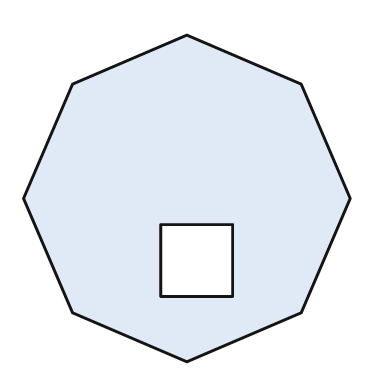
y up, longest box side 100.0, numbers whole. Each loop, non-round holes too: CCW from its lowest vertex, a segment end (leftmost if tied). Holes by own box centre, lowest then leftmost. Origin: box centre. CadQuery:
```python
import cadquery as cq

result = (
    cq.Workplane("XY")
    .moveTo(0.0, -50.0)
    .lineTo(35.0, -35.0)
    .lineTo(50.0, 0.0)
    .lineTo(35.0, 35.0)
    .lineTo(0.0, 50.0)
    .lineTo(-35.0, 35.0)
    .lineTo(-50.0, 0.0)
    .lineTo(-35.0, -35.0)
    .close()
    .moveTo(-8.0, -30.0)
    .lineTo(14.0, -30.0)
    .lineTo(14.0, -8.0)
    .lineTo(-8.0, -8.0)
    .close()
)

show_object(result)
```